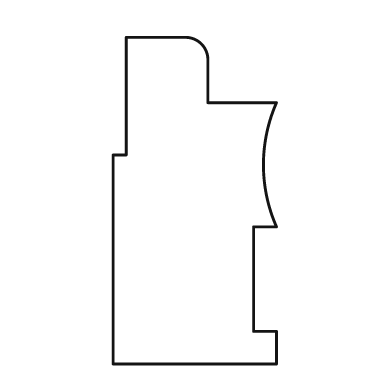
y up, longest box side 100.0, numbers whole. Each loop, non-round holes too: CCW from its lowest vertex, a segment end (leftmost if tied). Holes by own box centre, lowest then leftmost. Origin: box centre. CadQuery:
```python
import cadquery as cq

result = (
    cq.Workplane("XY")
    .moveTo(-25.0, -50.0)
    .lineTo(25.0, -50.0)
    .lineTo(25.0, -40.0)
    .lineTo(18.0, -40.0)
    .lineTo(18.0, -8.0)
    .lineTo(25.0, -8.0)
    .threePointArc((21.0, 11.0), (25.0, 30.0))
    .lineTo(4.0, 30.0)
    .lineTo(4.0, 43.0)
    .threePointArc((2.0, 48.0), (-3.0, 50.0))
    .lineTo(-21.0, 50.0)
    .lineTo(-21.0, 14.0)
    .lineTo(-25.0, 14.0)
    .close()
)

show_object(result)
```